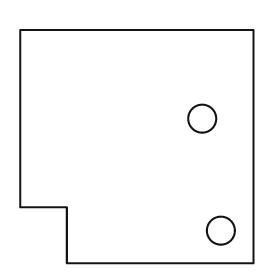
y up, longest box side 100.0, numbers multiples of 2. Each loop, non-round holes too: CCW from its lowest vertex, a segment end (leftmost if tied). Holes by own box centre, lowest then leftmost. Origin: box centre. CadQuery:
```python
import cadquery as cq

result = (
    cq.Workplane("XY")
    .moveTo(-30.0, -50.0)
    .lineTo(50.0, -50.0)
    .lineTo(50.0, 50.0)
    .lineTo(-50.0, 50.0)
    .lineTo(-50.0, -26.0)
    .lineTo(-30.0, -26.0)
    .close()
    .moveTo(36.0, -36.0)
    .circle(6.0)
    .moveTo(28.0, 12.0)
    .circle(6.0)
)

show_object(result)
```